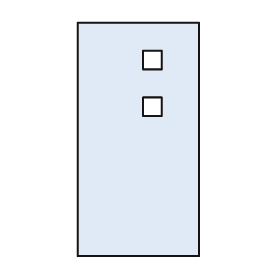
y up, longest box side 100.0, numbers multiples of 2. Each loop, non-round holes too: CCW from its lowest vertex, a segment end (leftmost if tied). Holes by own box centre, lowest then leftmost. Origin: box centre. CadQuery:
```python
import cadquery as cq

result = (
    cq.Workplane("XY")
    .moveTo(-26.0, -50.0)
    .lineTo(26.0, -50.0)
    .lineTo(26.0, 50.0)
    .lineTo(-26.0, 50.0)
    .close()
    .moveTo(2.0, 10.0)
    .lineTo(10.0, 10.0)
    .lineTo(10.0, 18.0)
    .lineTo(2.0, 18.0)
    .close()
    .moveTo(2.0, 30.0)
    .lineTo(10.0, 30.0)
    .lineTo(10.0, 38.0)
    .lineTo(2.0, 38.0)
    .close()
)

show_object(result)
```